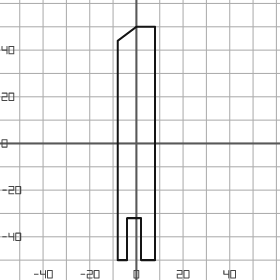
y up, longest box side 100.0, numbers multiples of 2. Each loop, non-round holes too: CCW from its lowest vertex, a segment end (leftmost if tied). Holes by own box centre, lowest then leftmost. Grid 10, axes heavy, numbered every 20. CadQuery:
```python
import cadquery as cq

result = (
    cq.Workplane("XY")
    .moveTo(-8.0, -50.0)
    .lineTo(-4.0, -50.0)
    .lineTo(-4.0, -32.0)
    .lineTo(2.0, -32.0)
    .lineTo(2.0, -50.0)
    .lineTo(8.0, -50.0)
    .lineTo(8.0, 50.0)
    .lineTo(0.0, 50.0)
    .lineTo(-8.0, 44.0)
    .close()
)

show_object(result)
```